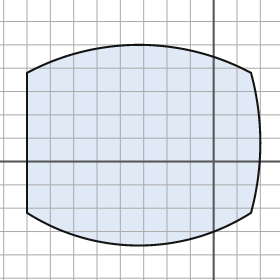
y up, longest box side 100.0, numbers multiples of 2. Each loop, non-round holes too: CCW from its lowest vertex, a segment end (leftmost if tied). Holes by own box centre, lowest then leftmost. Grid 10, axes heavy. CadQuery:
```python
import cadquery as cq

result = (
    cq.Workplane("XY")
    .moveTo(-80.0, -22.0)
    .threePointArc((-32.0, -36.0), (16.0, -22.0))
    .threePointArc((20.0, 8.0), (16.0, 38.0))
    .threePointArc((-32.0, 50.0), (-80.0, 38.0))
    .close()
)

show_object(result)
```